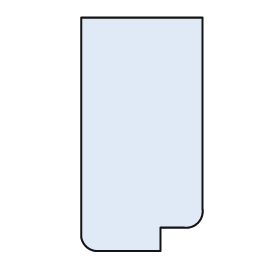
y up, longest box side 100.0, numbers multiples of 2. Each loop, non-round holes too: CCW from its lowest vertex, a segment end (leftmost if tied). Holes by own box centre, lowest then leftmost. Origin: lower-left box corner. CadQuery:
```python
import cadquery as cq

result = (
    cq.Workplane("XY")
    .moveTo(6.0, 0.0)
    .lineTo(34.0, 0.0)
    .lineTo(34.0, 10.0)
    .lineTo(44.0, 10.0)
    .threePointArc((50.0, 12.0), (52.0, 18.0))
    .lineTo(52.0, 100.0)
    .lineTo(0.0, 100.0)
    .lineTo(0.0, 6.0)
    .threePointArc((2.0, 2.0), (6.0, 0.0))
    .close()
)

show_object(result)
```